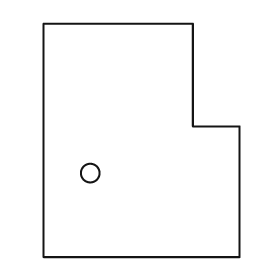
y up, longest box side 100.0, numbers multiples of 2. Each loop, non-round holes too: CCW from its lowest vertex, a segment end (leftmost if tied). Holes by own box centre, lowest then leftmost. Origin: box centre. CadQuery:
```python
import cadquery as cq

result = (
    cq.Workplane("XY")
    .moveTo(-42.0, -50.0)
    .lineTo(42.0, -50.0)
    .lineTo(42.0, 6.0)
    .lineTo(22.0, 6.0)
    .lineTo(22.0, 50.0)
    .lineTo(-42.0, 50.0)
    .close()
    .moveTo(-22.0, -14.0)
    .circle(4.0)
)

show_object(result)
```